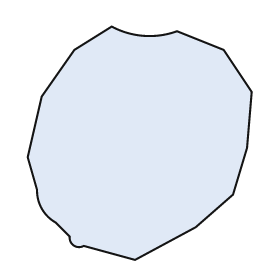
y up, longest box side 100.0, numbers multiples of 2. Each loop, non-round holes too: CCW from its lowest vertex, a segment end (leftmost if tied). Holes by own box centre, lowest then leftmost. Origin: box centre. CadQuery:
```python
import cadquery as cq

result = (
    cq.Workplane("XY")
    .moveTo(-2.0, -50.0)
    .lineTo(24.0, -36.0)
    .lineTo(40.0, -22.0)
    .lineTo(46.0, -2.0)
    .lineTo(48.0, 22.0)
    .lineTo(36.0, 40.0)
    .lineTo(16.0, 48.0)
    .threePointArc((2.0, 46.0), (-12.0, 50.0))
    .lineTo(-28.0, 40.0)
    .lineTo(-42.0, 20.0)
    .lineTo(-48.0, -6.0)
    .lineTo(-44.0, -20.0)
    .threePointArc((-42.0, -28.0), (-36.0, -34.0))
    .lineTo(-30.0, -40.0)
    .threePointArc((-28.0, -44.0), (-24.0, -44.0))
    .close()
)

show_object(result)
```